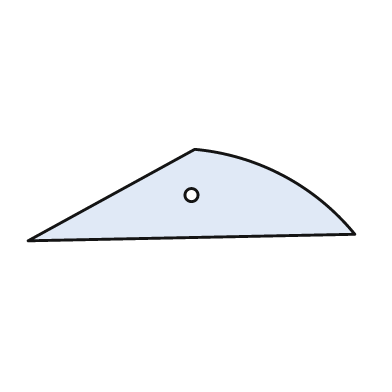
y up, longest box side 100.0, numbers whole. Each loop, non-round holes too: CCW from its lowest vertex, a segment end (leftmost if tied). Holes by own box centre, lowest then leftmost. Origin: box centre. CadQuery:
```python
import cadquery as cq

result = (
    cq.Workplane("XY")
    .moveTo(-50.0, -14.0)
    .lineTo(50.0, -12.0)
    .threePointArc((28.0, 6.0), (1.0, 14.0))
    .close()
    .moveTo(0.0, 0.0)
    .circle(2.0)
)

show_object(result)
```